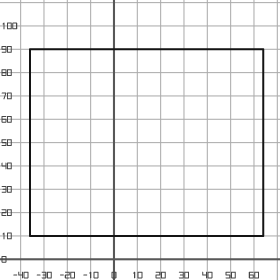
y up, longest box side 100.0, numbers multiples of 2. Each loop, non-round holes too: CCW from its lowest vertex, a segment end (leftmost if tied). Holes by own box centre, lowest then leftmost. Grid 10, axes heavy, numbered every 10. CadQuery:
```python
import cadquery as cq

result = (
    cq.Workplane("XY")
    .moveTo(-36.0, 10.0)
    .lineTo(64.0, 10.0)
    .lineTo(64.0, 90.0)
    .lineTo(-36.0, 90.0)
    .close()
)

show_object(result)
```